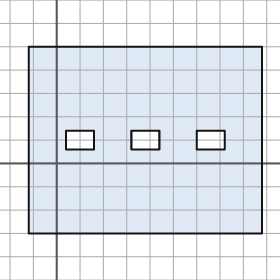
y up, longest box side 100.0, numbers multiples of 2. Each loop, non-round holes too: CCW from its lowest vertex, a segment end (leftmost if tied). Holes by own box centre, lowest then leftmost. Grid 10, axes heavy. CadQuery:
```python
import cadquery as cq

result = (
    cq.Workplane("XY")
    .moveTo(-12.0, -30.0)
    .lineTo(88.0, -30.0)
    .lineTo(88.0, 50.0)
    .lineTo(-12.0, 50.0)
    .close()
    .moveTo(4.0, 6.0)
    .lineTo(16.0, 6.0)
    .lineTo(16.0, 14.0)
    .lineTo(4.0, 14.0)
    .close()
    .moveTo(32.0, 6.0)
    .lineTo(44.0, 6.0)
    .lineTo(44.0, 14.0)
    .lineTo(32.0, 14.0)
    .close()
    .moveTo(60.0, 6.0)
    .lineTo(72.0, 6.0)
    .lineTo(72.0, 14.0)
    .lineTo(60.0, 14.0)
    .close()
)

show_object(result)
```